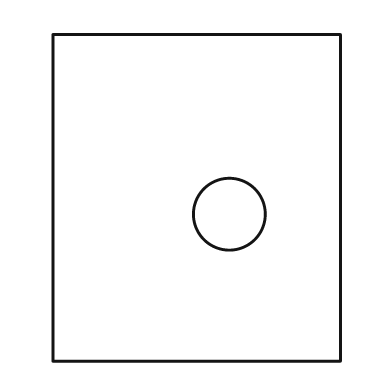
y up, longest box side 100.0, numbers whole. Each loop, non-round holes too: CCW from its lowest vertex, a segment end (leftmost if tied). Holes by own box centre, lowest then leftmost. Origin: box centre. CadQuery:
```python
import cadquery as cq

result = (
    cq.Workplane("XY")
    .moveTo(-44.0, -50.0)
    .lineTo(44.0, -50.0)
    .lineTo(44.0, 50.0)
    .lineTo(-44.0, 50.0)
    .close()
    .moveTo(10.0, -5.0)
    .circle(11.0)
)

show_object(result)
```